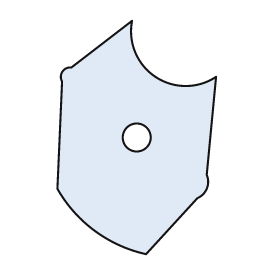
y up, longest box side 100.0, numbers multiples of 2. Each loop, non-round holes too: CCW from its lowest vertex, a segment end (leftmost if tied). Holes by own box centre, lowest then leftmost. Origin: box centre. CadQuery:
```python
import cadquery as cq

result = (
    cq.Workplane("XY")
    .moveTo(4.0, -50.0)
    .lineTo(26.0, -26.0)
    .threePointArc((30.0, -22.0), (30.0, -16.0))
    .lineTo(34.0, 26.0)
    .threePointArc((8.0, 26.0), (-2.0, 50.0))
    .lineTo(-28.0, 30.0)
    .threePointArc((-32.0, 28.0), (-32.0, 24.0))
    .lineTo(-34.0, -22.0)
    .threePointArc((-18.0, -40.0), (4.0, -50.0))
    .close()
    .moveTo(0.0, 0.0)
    .circle(6.0)
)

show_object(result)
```